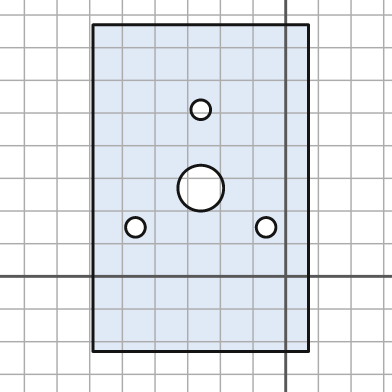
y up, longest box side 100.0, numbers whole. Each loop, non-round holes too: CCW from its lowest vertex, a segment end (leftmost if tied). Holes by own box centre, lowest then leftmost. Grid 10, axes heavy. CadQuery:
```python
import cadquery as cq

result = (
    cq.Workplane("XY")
    .moveTo(-59.0, -23.0)
    .lineTo(7.0, -23.0)
    .lineTo(7.0, 77.0)
    .lineTo(-59.0, 77.0)
    .close()
    .moveTo(-46.0, 15.0)
    .circle(3.0)
    .moveTo(-6.0, 15.0)
    .circle(3.0)
    .moveTo(-26.0, 27.0)
    .circle(7.0)
    .moveTo(-26.0, 51.0)
    .circle(3.0)
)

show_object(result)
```